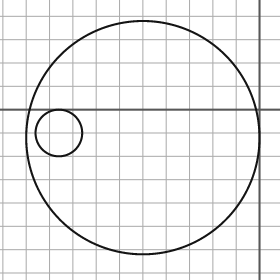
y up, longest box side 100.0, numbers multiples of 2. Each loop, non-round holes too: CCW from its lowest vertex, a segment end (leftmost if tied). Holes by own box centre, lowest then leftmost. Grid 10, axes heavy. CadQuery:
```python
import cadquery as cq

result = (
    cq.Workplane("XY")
    .moveTo(-50.0, -12.0)
    .circle(50.0)
    .moveTo(-86.0, -10.0)
    .circle(10.0)
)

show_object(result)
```